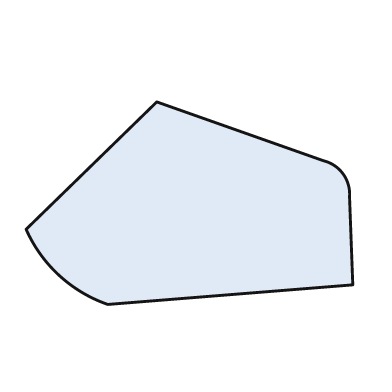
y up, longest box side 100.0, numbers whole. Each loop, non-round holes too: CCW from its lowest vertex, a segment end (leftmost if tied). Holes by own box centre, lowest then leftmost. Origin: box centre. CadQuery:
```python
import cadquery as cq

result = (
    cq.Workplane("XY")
    .moveTo(-25.0, -31.0)
    .lineTo(50.0, -25.0)
    .lineTo(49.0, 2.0)
    .threePointArc((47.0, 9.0), (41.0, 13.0))
    .lineTo(-10.0, 31.0)
    .lineTo(-50.0, -8.0)
    .threePointArc((-40.0, -22.0), (-25.0, -31.0))
    .close()
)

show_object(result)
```